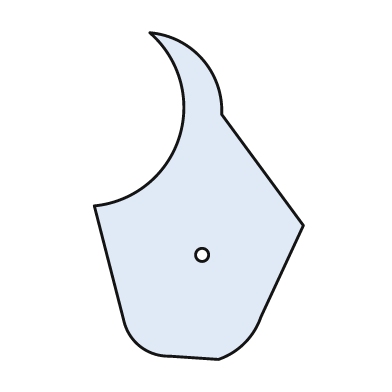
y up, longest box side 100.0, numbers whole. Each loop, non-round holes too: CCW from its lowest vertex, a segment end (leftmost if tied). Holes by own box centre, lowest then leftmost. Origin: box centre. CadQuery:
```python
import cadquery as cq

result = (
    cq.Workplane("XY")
    .moveTo(6.0, -50.0)
    .threePointArc((14.0, -45.0), (19.0, -37.0))
    .lineTo(32.0, -9.0)
    .lineTo(7.0, 25.0)
    .threePointArc((1.0, 42.0), (-15.0, 50.0))
    .threePointArc((-6.0, 18.0), (-32.0, -3.0))
    .lineTo(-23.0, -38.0)
    .threePointArc((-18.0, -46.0), (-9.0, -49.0))
    .close()
    .moveTo(1.0, -18.0)
    .circle(2.0)
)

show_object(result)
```